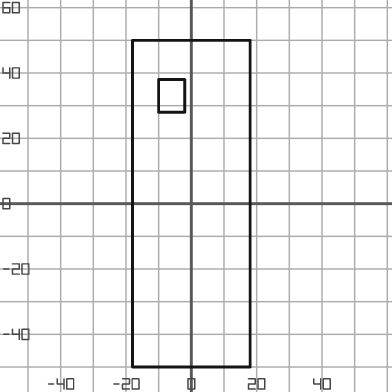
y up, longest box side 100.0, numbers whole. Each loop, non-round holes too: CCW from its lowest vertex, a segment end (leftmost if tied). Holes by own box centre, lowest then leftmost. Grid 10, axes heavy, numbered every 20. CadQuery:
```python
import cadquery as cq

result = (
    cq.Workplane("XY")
    .moveTo(-18.0, -50.0)
    .lineTo(18.0, -50.0)
    .lineTo(18.0, 50.0)
    .lineTo(-18.0, 50.0)
    .close()
    .moveTo(-10.0, 28.0)
    .lineTo(-2.0, 28.0)
    .lineTo(-2.0, 38.0)
    .lineTo(-10.0, 38.0)
    .close()
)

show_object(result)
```